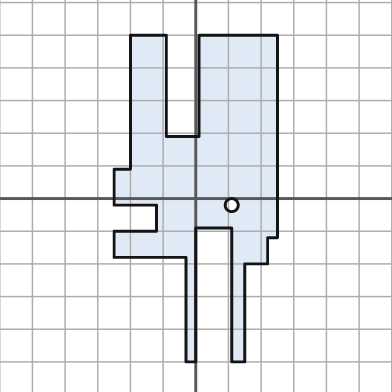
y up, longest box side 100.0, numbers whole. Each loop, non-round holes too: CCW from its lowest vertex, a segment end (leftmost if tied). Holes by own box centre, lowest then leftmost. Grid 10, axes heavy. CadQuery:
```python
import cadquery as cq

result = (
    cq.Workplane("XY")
    .moveTo(-3.0, -50.0)
    .lineTo(0.0, -50.0)
    .lineTo(0.0, -9.0)
    .lineTo(11.0, -9.0)
    .lineTo(11.0, -50.0)
    .lineTo(15.0, -50.0)
    .lineTo(15.0, -20.0)
    .lineTo(22.0, -20.0)
    .lineTo(22.0, -12.0)
    .lineTo(25.0, -12.0)
    .lineTo(25.0, 50.0)
    .lineTo(1.0, 50.0)
    .lineTo(1.0, 19.0)
    .lineTo(-9.0, 19.0)
    .lineTo(-9.0, 50.0)
    .lineTo(-20.0, 50.0)
    .lineTo(-20.0, 9.0)
    .lineTo(-25.0, 9.0)
    .lineTo(-25.0, -2.0)
    .lineTo(-12.0, -2.0)
    .lineTo(-12.0, -10.0)
    .lineTo(-25.0, -10.0)
    .lineTo(-25.0, -18.0)
    .lineTo(-3.0, -18.0)
    .close()
    .moveTo(11.0, -2.0)
    .circle(2.0)
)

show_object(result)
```